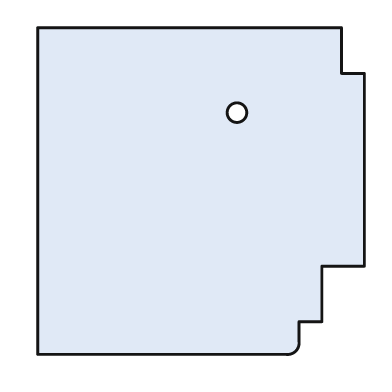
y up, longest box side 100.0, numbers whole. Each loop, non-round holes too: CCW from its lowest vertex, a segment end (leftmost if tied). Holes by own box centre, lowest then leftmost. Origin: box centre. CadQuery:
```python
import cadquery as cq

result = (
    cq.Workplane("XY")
    .moveTo(-50.0, -50.0)
    .lineTo(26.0, -50.0)
    .threePointArc((29.0, -49.0), (30.0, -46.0))
    .lineTo(30.0, -40.0)
    .lineTo(37.0, -40.0)
    .lineTo(37.0, -23.0)
    .lineTo(50.0, -23.0)
    .lineTo(50.0, 36.0)
    .lineTo(43.0, 36.0)
    .lineTo(43.0, 50.0)
    .lineTo(-50.0, 50.0)
    .close()
    .moveTo(11.0, 24.0)
    .circle(3.0)
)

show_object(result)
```